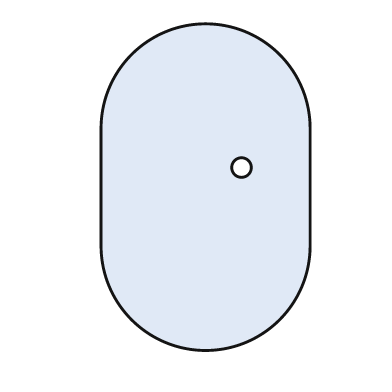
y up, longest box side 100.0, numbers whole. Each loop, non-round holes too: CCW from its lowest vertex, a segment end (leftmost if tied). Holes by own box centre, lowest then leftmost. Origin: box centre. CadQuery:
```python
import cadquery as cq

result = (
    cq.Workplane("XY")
    .moveTo(-32.0, -18.0)
    .threePointArc((0.0, -50.0), (32.0, -18.0))
    .lineTo(32.0, 18.0)
    .threePointArc((0.0, 50.0), (-32.0, 18.0))
    .close()
    .moveTo(11.0, 6.0)
    .circle(3.0)
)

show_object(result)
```